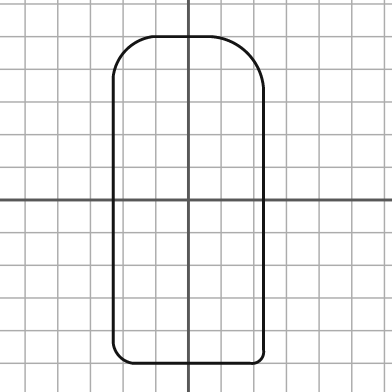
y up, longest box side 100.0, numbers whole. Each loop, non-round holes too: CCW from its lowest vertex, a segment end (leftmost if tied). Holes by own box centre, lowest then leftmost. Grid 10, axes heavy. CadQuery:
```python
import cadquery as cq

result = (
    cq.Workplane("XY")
    .moveTo(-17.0, -50.0)
    .lineTo(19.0, -50.0)
    .threePointArc((22.0, -49.0), (23.0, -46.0))
    .lineTo(23.0, 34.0)
    .threePointArc((18.0, 45.0), (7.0, 50.0))
    .lineTo(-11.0, 50.0)
    .threePointArc((-19.0, 46.0), (-23.0, 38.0))
    .lineTo(-23.0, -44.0)
    .threePointArc((-21.0, -48.0), (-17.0, -50.0))
    .close()
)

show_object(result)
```